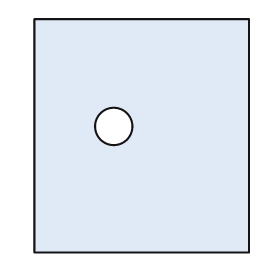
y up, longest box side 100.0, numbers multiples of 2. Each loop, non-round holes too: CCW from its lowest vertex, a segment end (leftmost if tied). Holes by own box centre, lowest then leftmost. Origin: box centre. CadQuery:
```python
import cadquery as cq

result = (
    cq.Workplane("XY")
    .moveTo(-46.0, -50.0)
    .lineTo(46.0, -50.0)
    .lineTo(46.0, 50.0)
    .lineTo(-46.0, 50.0)
    .close()
    .moveTo(-12.0, 4.0)
    .circle(8.0)
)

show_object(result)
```